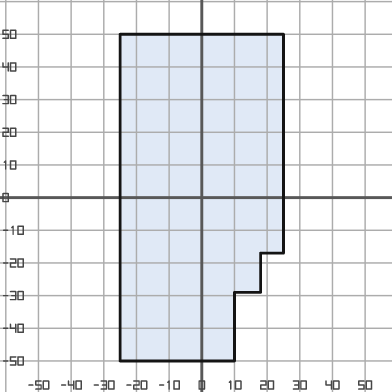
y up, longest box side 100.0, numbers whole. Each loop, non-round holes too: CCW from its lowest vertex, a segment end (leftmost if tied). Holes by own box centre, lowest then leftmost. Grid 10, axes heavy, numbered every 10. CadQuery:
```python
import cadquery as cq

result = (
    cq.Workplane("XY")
    .moveTo(-25.0, -50.0)
    .lineTo(10.0, -50.0)
    .lineTo(10.0, -29.0)
    .lineTo(18.0, -29.0)
    .lineTo(18.0, -17.0)
    .lineTo(25.0, -17.0)
    .lineTo(25.0, 50.0)
    .lineTo(-25.0, 50.0)
    .close()
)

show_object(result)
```